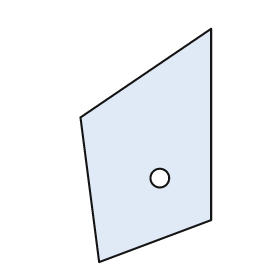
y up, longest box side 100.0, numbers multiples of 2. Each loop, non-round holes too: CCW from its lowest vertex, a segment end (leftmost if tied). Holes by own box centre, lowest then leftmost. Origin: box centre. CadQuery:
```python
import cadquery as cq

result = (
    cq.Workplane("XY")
    .moveTo(-20.0, -50.0)
    .lineTo(28.0, -32.0)
    .lineTo(28.0, 50.0)
    .lineTo(-28.0, 12.0)
    .close()
    .moveTo(6.0, -14.0)
    .circle(4.0)
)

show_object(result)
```